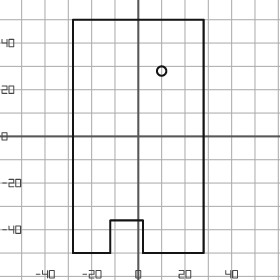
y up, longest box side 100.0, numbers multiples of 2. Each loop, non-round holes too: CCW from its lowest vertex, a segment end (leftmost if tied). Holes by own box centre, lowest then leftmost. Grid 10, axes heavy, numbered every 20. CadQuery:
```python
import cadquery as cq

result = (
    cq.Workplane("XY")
    .moveTo(-28.0, -50.0)
    .lineTo(-12.0, -50.0)
    .lineTo(-12.0, -36.0)
    .lineTo(2.0, -36.0)
    .lineTo(2.0, -50.0)
    .lineTo(28.0, -50.0)
    .lineTo(28.0, 50.0)
    .lineTo(-28.0, 50.0)
    .close()
    .moveTo(10.0, 28.0)
    .circle(2.0)
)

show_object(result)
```